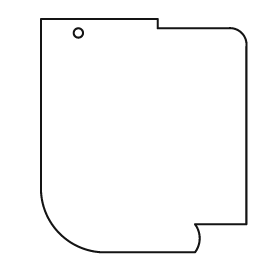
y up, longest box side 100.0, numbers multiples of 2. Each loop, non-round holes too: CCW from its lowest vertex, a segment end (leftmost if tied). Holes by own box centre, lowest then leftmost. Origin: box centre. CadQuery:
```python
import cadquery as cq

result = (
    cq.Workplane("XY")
    .moveTo(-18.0, -50.0)
    .lineTo(22.0, -50.0)
    .threePointArc((24.0, -44.0), (22.0, -38.0))
    .lineTo(44.0, -38.0)
    .lineTo(44.0, 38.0)
    .threePointArc((42.0, 44.0), (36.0, 46.0))
    .lineTo(6.0, 46.0)
    .lineTo(6.0, 50.0)
    .lineTo(-44.0, 50.0)
    .lineTo(-44.0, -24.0)
    .threePointArc((-36.0, -42.0), (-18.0, -50.0))
    .close()
    .moveTo(-28.0, 44.0)
    .circle(2.0)
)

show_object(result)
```